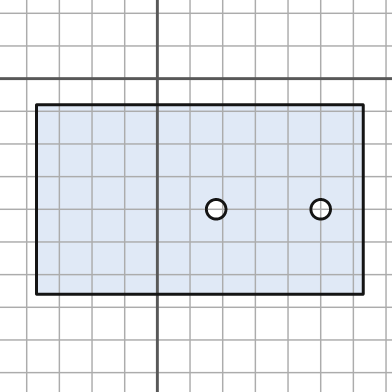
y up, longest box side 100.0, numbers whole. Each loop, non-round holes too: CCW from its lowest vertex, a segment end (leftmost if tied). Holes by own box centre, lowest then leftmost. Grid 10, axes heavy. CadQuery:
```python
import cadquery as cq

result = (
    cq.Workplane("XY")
    .moveTo(-37.0, -66.0)
    .lineTo(63.0, -66.0)
    .lineTo(63.0, -8.0)
    .lineTo(-37.0, -8.0)
    .close()
    .moveTo(18.0, -40.0)
    .circle(3.0)
    .moveTo(50.0, -40.0)
    .circle(3.0)
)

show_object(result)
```